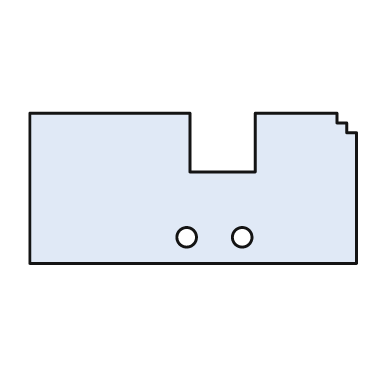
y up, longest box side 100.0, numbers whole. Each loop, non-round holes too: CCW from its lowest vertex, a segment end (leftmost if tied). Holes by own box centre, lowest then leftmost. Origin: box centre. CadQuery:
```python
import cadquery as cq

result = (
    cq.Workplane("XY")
    .moveTo(-50.0, -23.0)
    .lineTo(50.0, -23.0)
    .lineTo(50.0, 17.0)
    .lineTo(47.0, 17.0)
    .lineTo(47.0, 20.0)
    .lineTo(44.0, 20.0)
    .lineTo(44.0, 23.0)
    .lineTo(19.0, 23.0)
    .lineTo(19.0, 5.0)
    .lineTo(-1.0, 5.0)
    .lineTo(-1.0, 23.0)
    .lineTo(-50.0, 23.0)
    .close()
    .moveTo(-2.0, -15.0)
    .circle(3.0)
    .moveTo(15.0, -15.0)
    .circle(3.0)
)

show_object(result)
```